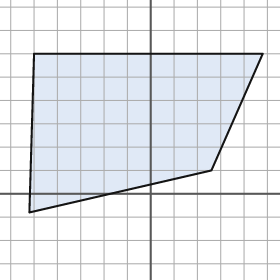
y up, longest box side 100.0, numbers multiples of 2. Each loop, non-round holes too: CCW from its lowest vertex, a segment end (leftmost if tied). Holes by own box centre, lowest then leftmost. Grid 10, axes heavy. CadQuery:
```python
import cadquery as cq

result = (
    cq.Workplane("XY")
    .moveTo(-52.0, -8.0)
    .lineTo(26.0, 10.0)
    .lineTo(48.0, 60.0)
    .lineTo(-50.0, 60.0)
    .close()
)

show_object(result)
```